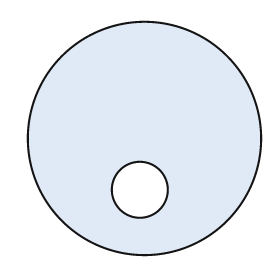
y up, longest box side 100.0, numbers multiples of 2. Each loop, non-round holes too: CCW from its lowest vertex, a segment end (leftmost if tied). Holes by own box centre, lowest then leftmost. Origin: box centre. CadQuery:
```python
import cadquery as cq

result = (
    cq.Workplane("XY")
    .moveTo(0.0, 0.0)
    .circle(50.0)
    .moveTo(-2.0, -22.0)
    .circle(12.0)
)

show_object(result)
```